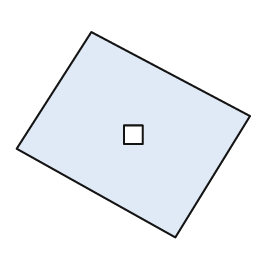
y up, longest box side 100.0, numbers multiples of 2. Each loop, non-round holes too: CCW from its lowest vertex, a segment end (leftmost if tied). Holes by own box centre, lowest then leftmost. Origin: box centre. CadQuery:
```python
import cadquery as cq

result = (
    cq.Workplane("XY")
    .moveTo(18.0, -44.0)
    .lineTo(50.0, 8.0)
    .lineTo(-18.0, 44.0)
    .lineTo(-50.0, -6.0)
    .close()
    .moveTo(-4.0, -4.0)
    .lineTo(4.0, -4.0)
    .lineTo(4.0, 4.0)
    .lineTo(-4.0, 4.0)
    .close()
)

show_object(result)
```